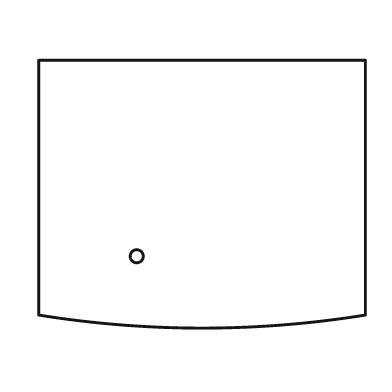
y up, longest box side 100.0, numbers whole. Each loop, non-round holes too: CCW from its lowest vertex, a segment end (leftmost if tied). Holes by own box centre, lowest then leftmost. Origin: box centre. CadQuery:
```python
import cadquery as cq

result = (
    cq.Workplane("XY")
    .moveTo(-50.0, -37.0)
    .threePointArc((0.0, -41.0), (50.0, -37.0))
    .lineTo(50.0, 41.0)
    .lineTo(-50.0, 41.0)
    .close()
    .moveTo(-20.0, -19.0)
    .circle(2.0)
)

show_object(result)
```